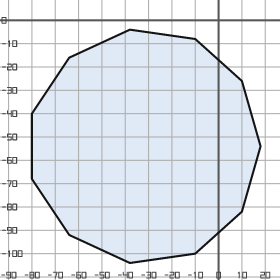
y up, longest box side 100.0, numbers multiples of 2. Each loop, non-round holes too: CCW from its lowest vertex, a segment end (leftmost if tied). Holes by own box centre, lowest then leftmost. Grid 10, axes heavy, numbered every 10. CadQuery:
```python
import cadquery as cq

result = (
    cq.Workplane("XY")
    .moveTo(-38.0, -104.0)
    .lineTo(-10.0, -100.0)
    .lineTo(10.0, -82.0)
    .lineTo(18.0, -54.0)
    .lineTo(10.0, -26.0)
    .lineTo(-10.0, -8.0)
    .lineTo(-38.0, -4.0)
    .lineTo(-64.0, -16.0)
    .lineTo(-80.0, -40.0)
    .lineTo(-80.0, -68.0)
    .lineTo(-64.0, -92.0)
    .close()
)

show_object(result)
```